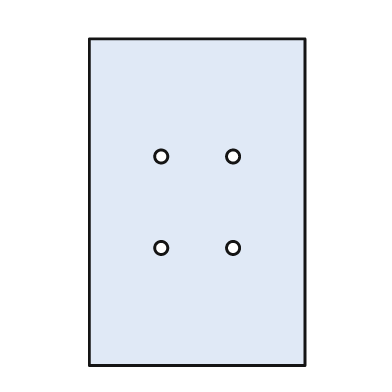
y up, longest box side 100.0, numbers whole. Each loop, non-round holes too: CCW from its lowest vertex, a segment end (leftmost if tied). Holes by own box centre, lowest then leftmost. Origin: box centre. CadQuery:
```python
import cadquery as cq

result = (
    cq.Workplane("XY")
    .moveTo(-33.0, -50.0)
    .lineTo(33.0, -50.0)
    .lineTo(33.0, 50.0)
    .lineTo(-33.0, 50.0)
    .close()
    .moveTo(-11.0, -14.0)
    .circle(2.0)
    .moveTo(11.0, -14.0)
    .circle(2.0)
    .moveTo(-11.0, 14.0)
    .circle(2.0)
    .moveTo(11.0, 14.0)
    .circle(2.0)
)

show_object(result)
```